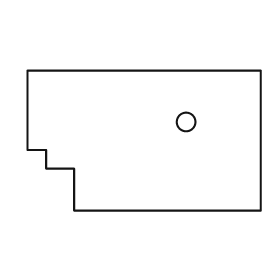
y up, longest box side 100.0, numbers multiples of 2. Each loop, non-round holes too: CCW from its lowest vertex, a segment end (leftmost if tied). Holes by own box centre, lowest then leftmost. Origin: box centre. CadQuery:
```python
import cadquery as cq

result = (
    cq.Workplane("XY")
    .moveTo(-30.0, -30.0)
    .lineTo(50.0, -30.0)
    .lineTo(50.0, 30.0)
    .lineTo(-50.0, 30.0)
    .lineTo(-50.0, -4.0)
    .lineTo(-42.0, -4.0)
    .lineTo(-42.0, -12.0)
    .lineTo(-30.0, -12.0)
    .close()
    .moveTo(18.0, 8.0)
    .circle(4.0)
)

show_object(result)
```